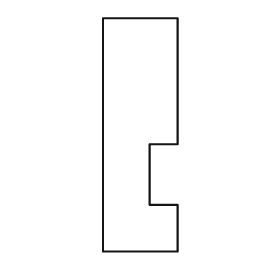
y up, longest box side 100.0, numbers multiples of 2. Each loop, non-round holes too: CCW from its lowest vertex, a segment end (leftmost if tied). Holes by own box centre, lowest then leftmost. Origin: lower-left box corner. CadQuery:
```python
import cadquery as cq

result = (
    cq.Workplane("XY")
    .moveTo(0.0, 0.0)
    .lineTo(32.0, 0.0)
    .lineTo(32.0, 20.0)
    .lineTo(20.0, 20.0)
    .lineTo(20.0, 46.0)
    .lineTo(32.0, 46.0)
    .lineTo(32.0, 100.0)
    .lineTo(0.0, 100.0)
    .close()
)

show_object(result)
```